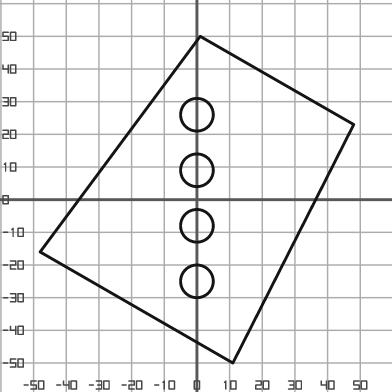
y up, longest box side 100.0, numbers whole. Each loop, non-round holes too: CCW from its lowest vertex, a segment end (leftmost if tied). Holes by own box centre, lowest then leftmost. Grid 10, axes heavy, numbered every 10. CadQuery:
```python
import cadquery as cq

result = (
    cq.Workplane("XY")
    .moveTo(11.0, -50.0)
    .lineTo(48.0, 23.0)
    .lineTo(1.0, 50.0)
    .lineTo(-48.0, -16.0)
    .close()
    .moveTo(0.0, -25.0)
    .circle(5.0)
    .moveTo(0.0, -8.0)
    .circle(5.0)
    .moveTo(0.0, 9.0)
    .circle(5.0)
    .moveTo(0.0, 26.0)
    .circle(5.0)
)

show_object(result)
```